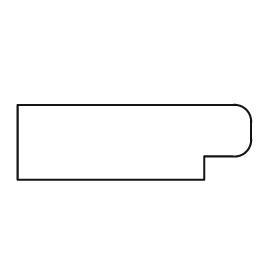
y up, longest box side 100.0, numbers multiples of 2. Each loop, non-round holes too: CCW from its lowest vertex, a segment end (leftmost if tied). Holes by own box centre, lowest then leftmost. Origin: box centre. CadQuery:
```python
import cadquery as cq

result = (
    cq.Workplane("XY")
    .moveTo(-50.0, -16.0)
    .lineTo(30.0, -16.0)
    .lineTo(30.0, -6.0)
    .lineTo(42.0, -6.0)
    .threePointArc((48.0, -4.0), (50.0, 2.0))
    .lineTo(50.0, 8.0)
    .threePointArc((48.0, 14.0), (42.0, 16.0))
    .lineTo(-50.0, 16.0)
    .close()
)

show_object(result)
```